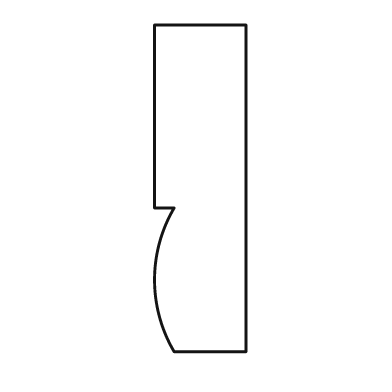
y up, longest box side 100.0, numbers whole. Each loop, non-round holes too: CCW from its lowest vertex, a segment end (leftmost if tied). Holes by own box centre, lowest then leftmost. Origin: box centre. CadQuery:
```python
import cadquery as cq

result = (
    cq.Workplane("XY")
    .moveTo(-8.0, -50.0)
    .lineTo(14.0, -50.0)
    .lineTo(14.0, 50.0)
    .lineTo(-14.0, 50.0)
    .lineTo(-14.0, -6.0)
    .lineTo(-8.0, -6.0)
    .threePointArc((-14.0, -28.0), (-8.0, -50.0))
    .close()
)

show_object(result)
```